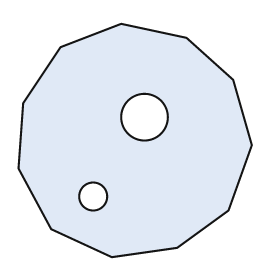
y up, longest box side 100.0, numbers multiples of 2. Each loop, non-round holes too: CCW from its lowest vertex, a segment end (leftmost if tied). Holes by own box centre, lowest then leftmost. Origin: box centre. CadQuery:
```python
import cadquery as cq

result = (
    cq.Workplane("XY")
    .moveTo(-10.0, -50.0)
    .lineTo(18.0, -46.0)
    .lineTo(40.0, -30.0)
    .lineTo(50.0, -2.0)
    .lineTo(42.0, 26.0)
    .lineTo(22.0, 44.0)
    .lineTo(-6.0, 50.0)
    .lineTo(-32.0, 40.0)
    .lineTo(-48.0, 16.0)
    .lineTo(-50.0, -12.0)
    .lineTo(-36.0, -38.0)
    .close()
    .moveTo(-18.0, -24.0)
    .circle(6.0)
    .moveTo(4.0, 10.0)
    .circle(10.0)
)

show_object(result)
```